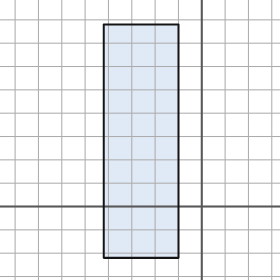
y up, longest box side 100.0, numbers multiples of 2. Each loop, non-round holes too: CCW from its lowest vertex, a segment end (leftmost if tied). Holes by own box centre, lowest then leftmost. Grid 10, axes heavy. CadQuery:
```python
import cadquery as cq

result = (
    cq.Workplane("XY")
    .moveTo(-42.0, -22.0)
    .lineTo(-10.0, -22.0)
    .lineTo(-10.0, 78.0)
    .lineTo(-42.0, 78.0)
    .close()
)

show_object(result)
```